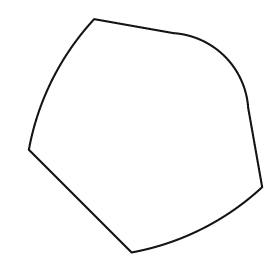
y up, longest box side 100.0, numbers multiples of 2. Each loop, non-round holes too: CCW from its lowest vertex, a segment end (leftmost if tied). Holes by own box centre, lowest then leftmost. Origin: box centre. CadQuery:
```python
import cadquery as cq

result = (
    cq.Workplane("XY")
    .moveTo(-6.0, -50.0)
    .threePointArc((24.0, -40.0), (50.0, -22.0))
    .lineTo(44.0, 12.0)
    .threePointArc((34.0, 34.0), (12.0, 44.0))
    .lineTo(-22.0, 50.0)
    .threePointArc((-40.0, 24.0), (-50.0, -6.0))
    .close()
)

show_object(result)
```